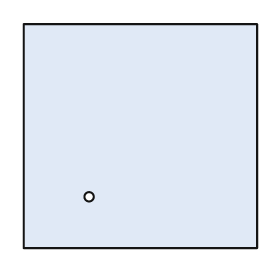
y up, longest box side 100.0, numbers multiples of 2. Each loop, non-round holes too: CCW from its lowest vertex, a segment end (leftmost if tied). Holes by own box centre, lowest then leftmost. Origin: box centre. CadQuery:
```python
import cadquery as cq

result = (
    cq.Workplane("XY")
    .moveTo(-50.0, -48.0)
    .lineTo(50.0, -48.0)
    .lineTo(50.0, 48.0)
    .lineTo(-50.0, 48.0)
    .close()
    .moveTo(-22.0, -26.0)
    .circle(2.0)
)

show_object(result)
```